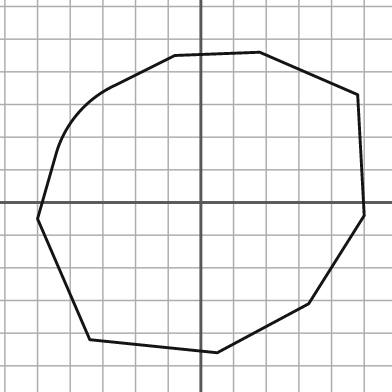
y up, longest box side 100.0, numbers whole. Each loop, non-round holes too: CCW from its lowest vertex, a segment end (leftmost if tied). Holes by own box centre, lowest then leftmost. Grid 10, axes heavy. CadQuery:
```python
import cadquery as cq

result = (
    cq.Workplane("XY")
    .moveTo(5.0, -46.0)
    .lineTo(33.0, -31.0)
    .lineTo(50.0, -4.0)
    .lineTo(48.0, 33.0)
    .lineTo(18.0, 46.0)
    .lineTo(-8.0, 45.0)
    .lineTo(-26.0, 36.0)
    .threePointArc((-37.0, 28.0), (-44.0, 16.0))
    .lineTo(-50.0, -5.0)
    .lineTo(-34.0, -42.0)
    .close()
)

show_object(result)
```